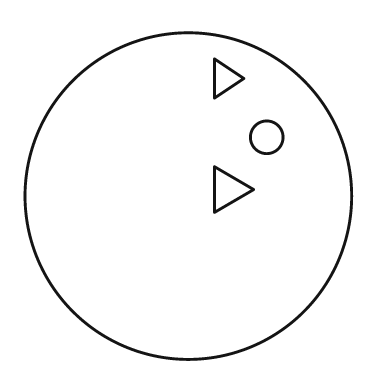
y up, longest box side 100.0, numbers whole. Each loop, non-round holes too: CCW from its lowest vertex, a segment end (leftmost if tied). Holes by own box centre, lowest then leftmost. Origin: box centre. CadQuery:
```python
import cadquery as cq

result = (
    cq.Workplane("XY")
    .moveTo(0.0, 0.0)
    .circle(50.0)
    .moveTo(8.0, -5.0)
    .lineTo(20.0, 2.0)
    .lineTo(8.0, 9.0)
    .close()
    .moveTo(24.0, 18.0)
    .circle(5.0)
    .moveTo(8.0, 30.0)
    .lineTo(17.0, 36.0)
    .lineTo(8.0, 42.0)
    .close()
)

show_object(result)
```